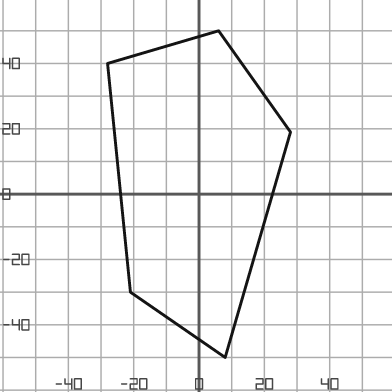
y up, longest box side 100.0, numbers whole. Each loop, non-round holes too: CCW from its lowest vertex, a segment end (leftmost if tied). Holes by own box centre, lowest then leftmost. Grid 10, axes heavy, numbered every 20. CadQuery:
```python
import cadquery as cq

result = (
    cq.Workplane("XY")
    .moveTo(8.0, -50.0)
    .lineTo(28.0, 19.0)
    .lineTo(6.0, 50.0)
    .lineTo(-28.0, 40.0)
    .lineTo(-21.0, -30.0)
    .close()
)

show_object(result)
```